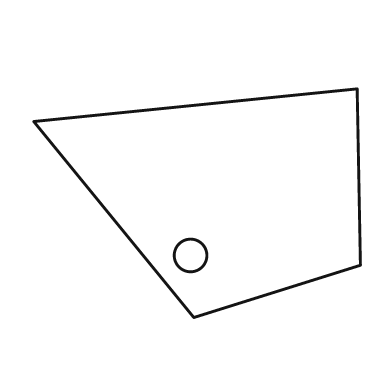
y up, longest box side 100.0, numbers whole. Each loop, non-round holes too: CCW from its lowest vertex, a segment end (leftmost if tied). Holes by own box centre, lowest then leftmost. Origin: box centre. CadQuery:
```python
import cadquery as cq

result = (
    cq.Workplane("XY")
    .moveTo(-1.0, -35.0)
    .lineTo(50.0, -19.0)
    .lineTo(49.0, 35.0)
    .lineTo(-50.0, 25.0)
    .close()
    .moveTo(-2.0, -16.0)
    .circle(5.0)
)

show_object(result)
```